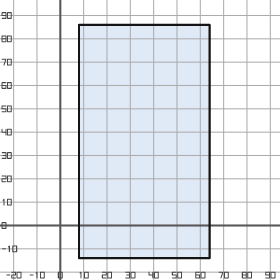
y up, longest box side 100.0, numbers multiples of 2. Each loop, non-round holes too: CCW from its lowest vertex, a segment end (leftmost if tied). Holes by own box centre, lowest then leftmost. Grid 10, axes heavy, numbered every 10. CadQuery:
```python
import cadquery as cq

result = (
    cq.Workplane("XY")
    .moveTo(8.0, -14.0)
    .lineTo(64.0, -14.0)
    .lineTo(64.0, 86.0)
    .lineTo(8.0, 86.0)
    .close()
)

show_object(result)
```